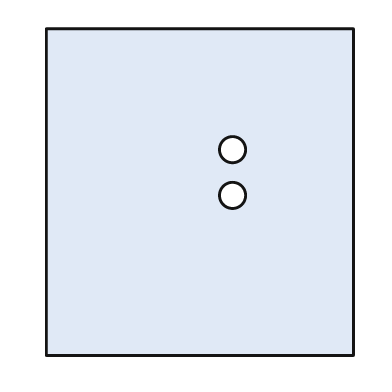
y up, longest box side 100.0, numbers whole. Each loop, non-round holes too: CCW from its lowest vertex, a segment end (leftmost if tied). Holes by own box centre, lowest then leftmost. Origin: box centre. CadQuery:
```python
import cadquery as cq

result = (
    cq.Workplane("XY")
    .moveTo(-47.0, -50.0)
    .lineTo(47.0, -50.0)
    .lineTo(47.0, 50.0)
    .lineTo(-47.0, 50.0)
    .close()
    .moveTo(10.0, -1.0)
    .circle(4.0)
    .moveTo(10.0, 13.0)
    .circle(4.0)
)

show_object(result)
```